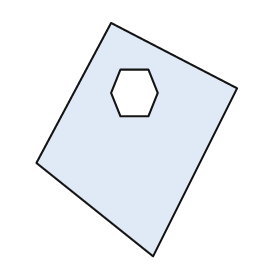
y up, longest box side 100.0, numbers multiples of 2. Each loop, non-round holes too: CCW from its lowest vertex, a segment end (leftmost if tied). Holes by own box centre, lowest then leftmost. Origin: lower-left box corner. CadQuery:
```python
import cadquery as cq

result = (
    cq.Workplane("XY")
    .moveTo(50.0, 0.0)
    .lineTo(86.0, 72.0)
    .lineTo(32.0, 100.0)
    .lineTo(0.0, 40.0)
    .close()
    .moveTo(36.0, 60.0)
    .lineTo(48.0, 60.0)
    .lineTo(52.0, 70.0)
    .lineTo(48.0, 80.0)
    .lineTo(36.0, 80.0)
    .lineTo(32.0, 70.0)
    .close()
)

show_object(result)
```